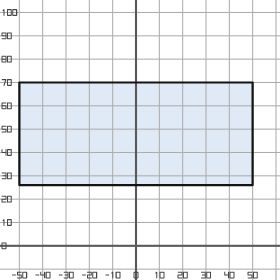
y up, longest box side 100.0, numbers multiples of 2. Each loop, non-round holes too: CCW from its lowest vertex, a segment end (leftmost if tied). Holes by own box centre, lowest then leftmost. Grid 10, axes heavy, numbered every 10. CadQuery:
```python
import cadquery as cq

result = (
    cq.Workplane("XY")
    .moveTo(-50.0, 26.0)
    .lineTo(50.0, 26.0)
    .lineTo(50.0, 70.0)
    .lineTo(-50.0, 70.0)
    .close()
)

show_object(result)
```